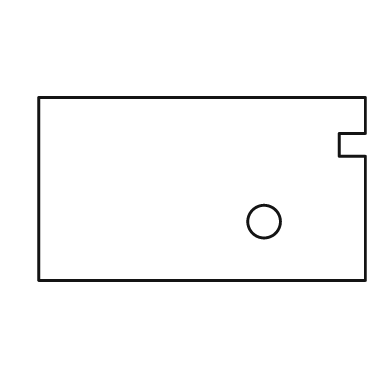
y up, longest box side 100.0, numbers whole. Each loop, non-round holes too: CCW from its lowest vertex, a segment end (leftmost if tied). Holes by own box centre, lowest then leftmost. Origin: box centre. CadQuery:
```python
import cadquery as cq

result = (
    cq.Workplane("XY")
    .moveTo(-50.0, -28.0)
    .lineTo(50.0, -28.0)
    .lineTo(50.0, 10.0)
    .lineTo(42.0, 10.0)
    .lineTo(42.0, 17.0)
    .lineTo(50.0, 17.0)
    .lineTo(50.0, 28.0)
    .lineTo(-50.0, 28.0)
    .close()
    .moveTo(19.0, -10.0)
    .circle(5.0)
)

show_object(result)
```